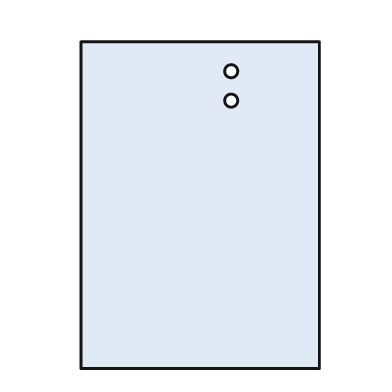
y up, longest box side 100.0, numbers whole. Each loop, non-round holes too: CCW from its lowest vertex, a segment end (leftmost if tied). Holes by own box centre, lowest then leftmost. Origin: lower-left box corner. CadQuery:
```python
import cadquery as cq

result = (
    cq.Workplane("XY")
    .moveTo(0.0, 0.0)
    .lineTo(73.0, 0.0)
    .lineTo(73.0, 100.0)
    .lineTo(0.0, 100.0)
    .close()
    .moveTo(46.0, 82.0)
    .circle(2.0)
    .moveTo(46.0, 91.0)
    .circle(2.0)
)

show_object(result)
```